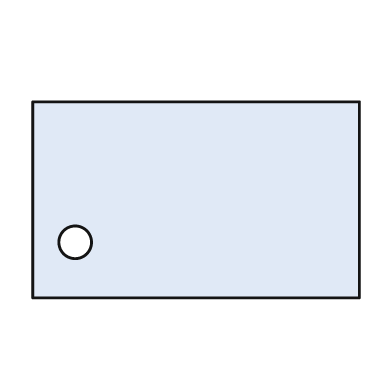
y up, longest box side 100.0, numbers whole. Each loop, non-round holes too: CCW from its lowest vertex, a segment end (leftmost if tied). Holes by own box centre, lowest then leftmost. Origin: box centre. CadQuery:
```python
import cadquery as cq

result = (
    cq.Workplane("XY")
    .moveTo(-50.0, -30.0)
    .lineTo(50.0, -30.0)
    .lineTo(50.0, 30.0)
    .lineTo(-50.0, 30.0)
    .close()
    .moveTo(-37.0, -13.0)
    .circle(5.0)
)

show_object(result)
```